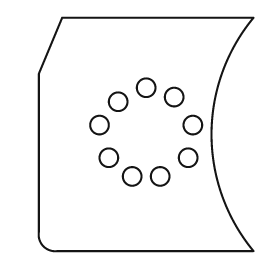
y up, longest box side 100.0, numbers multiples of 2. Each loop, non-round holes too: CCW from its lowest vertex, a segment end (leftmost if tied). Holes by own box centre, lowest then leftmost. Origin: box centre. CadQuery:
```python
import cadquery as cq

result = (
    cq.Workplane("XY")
    .moveTo(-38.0, -50.0)
    .lineTo(46.0, -50.0)
    .threePointArc((28.0, 0.0), (46.0, 50.0))
    .lineTo(-36.0, 50.0)
    .lineTo(-46.0, 26.0)
    .lineTo(-46.0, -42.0)
    .threePointArc((-44.0, -48.0), (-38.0, -50.0))
    .close()
    .moveTo(-6.0, -18.0)
    .circle(4.0)
    .moveTo(6.0, -18.0)
    .circle(4.0)
    .moveTo(-16.0, -10.0)
    .circle(4.0)
    .moveTo(18.0, -10.0)
    .circle(4.0)
    .moveTo(-20.0, 4.0)
    .circle(4.0)
    .moveTo(20.0, 4.0)
    .circle(4.0)
    .moveTo(-12.0, 14.0)
    .circle(4.0)
    .moveTo(12.0, 16.0)
    .circle(4.0)
    .moveTo(0.0, 20.0)
    .circle(4.0)
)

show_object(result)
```